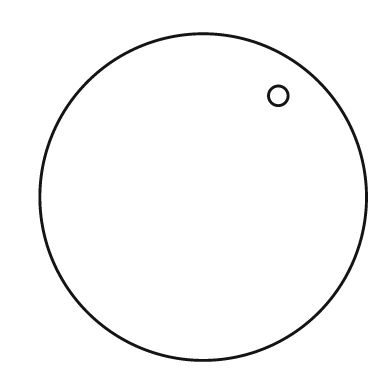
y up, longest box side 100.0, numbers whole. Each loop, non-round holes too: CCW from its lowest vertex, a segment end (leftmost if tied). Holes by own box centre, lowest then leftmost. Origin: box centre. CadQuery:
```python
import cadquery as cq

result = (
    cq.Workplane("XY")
    .moveTo(0.0, 0.0)
    .circle(50.0)
    .moveTo(23.0, 31.0)
    .circle(3.0)
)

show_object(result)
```